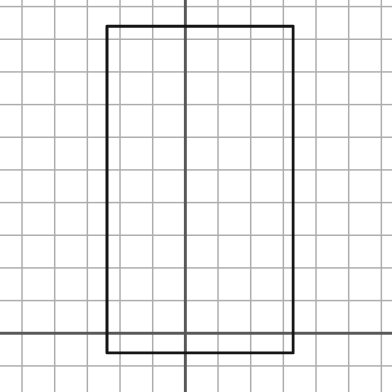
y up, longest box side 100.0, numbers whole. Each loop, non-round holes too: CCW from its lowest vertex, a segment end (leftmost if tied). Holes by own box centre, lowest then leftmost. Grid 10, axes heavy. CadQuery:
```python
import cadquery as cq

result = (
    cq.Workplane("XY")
    .moveTo(-24.0, -6.0)
    .lineTo(33.0, -6.0)
    .lineTo(33.0, 94.0)
    .lineTo(-24.0, 94.0)
    .close()
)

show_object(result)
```